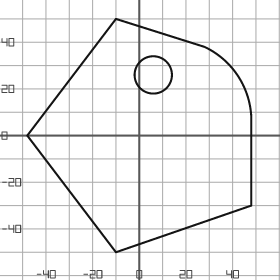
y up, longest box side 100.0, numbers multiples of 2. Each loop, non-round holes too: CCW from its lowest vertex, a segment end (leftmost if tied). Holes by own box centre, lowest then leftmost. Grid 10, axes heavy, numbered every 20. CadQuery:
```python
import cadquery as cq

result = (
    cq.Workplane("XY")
    .moveTo(-10.0, -50.0)
    .lineTo(48.0, -30.0)
    .lineTo(48.0, 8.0)
    .threePointArc((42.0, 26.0), (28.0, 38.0))
    .lineTo(-10.0, 50.0)
    .lineTo(-48.0, 0.0)
    .close()
    .moveTo(6.0, 26.0)
    .circle(8.0)
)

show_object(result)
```